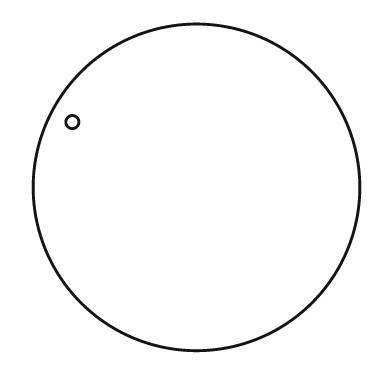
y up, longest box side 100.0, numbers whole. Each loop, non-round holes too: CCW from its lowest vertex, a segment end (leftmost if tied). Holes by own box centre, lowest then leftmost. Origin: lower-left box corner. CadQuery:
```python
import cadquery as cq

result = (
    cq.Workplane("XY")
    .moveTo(50.0, 50.0)
    .circle(50.0)
    .moveTo(12.0, 70.0)
    .circle(2.0)
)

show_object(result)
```